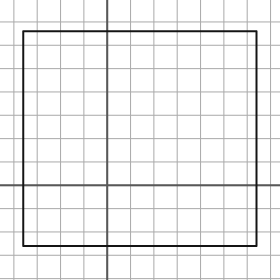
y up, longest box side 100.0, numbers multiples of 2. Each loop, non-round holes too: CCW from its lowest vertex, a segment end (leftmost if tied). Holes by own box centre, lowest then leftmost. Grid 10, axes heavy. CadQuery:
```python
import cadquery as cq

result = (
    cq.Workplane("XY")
    .moveTo(-36.0, -26.0)
    .lineTo(64.0, -26.0)
    .lineTo(64.0, 66.0)
    .lineTo(-36.0, 66.0)
    .close()
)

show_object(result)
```